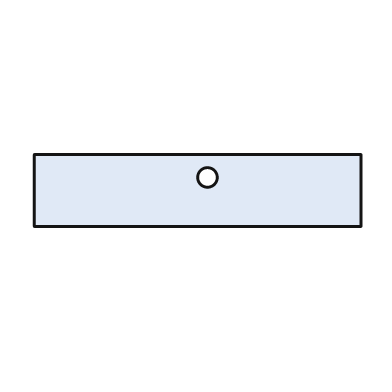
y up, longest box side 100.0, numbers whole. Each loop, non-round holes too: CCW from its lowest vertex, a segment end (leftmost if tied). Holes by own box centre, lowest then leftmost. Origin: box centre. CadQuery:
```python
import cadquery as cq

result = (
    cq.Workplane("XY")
    .moveTo(-50.0, -11.0)
    .lineTo(50.0, -11.0)
    .lineTo(50.0, 11.0)
    .lineTo(-50.0, 11.0)
    .close()
    .moveTo(3.0, 4.0)
    .circle(3.0)
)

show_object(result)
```